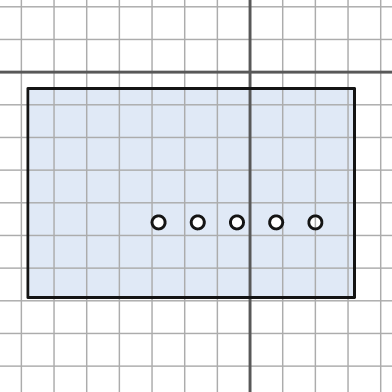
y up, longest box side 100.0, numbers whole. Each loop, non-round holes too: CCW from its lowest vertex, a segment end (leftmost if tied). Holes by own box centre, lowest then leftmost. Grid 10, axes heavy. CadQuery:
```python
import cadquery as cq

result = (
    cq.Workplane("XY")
    .moveTo(-68.0, -69.0)
    .lineTo(32.0, -69.0)
    .lineTo(32.0, -5.0)
    .lineTo(-68.0, -5.0)
    .close()
    .moveTo(-28.0, -46.0)
    .circle(2.0)
    .moveTo(-16.0, -46.0)
    .circle(2.0)
    .moveTo(-4.0, -46.0)
    .circle(2.0)
    .moveTo(8.0, -46.0)
    .circle(2.0)
    .moveTo(20.0, -46.0)
    .circle(2.0)
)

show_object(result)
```